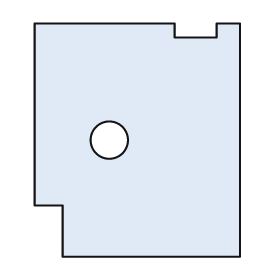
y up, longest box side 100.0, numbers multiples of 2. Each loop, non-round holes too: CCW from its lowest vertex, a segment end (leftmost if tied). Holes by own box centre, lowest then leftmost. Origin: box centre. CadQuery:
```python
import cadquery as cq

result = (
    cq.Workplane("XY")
    .moveTo(-32.0, -50.0)
    .lineTo(44.0, -50.0)
    .lineTo(44.0, 50.0)
    .lineTo(34.0, 50.0)
    .lineTo(34.0, 44.0)
    .lineTo(16.0, 44.0)
    .lineTo(16.0, 50.0)
    .lineTo(-44.0, 50.0)
    .lineTo(-44.0, -28.0)
    .lineTo(-32.0, -28.0)
    .close()
    .moveTo(-12.0, 0.0)
    .circle(8.0)
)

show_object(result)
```